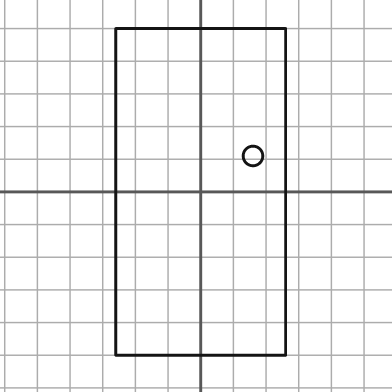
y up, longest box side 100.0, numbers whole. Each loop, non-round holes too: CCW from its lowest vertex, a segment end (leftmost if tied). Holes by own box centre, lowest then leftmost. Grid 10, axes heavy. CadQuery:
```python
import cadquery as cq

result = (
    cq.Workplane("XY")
    .moveTo(-26.0, -50.0)
    .lineTo(26.0, -50.0)
    .lineTo(26.0, 50.0)
    .lineTo(-26.0, 50.0)
    .close()
    .moveTo(16.0, 11.0)
    .circle(3.0)
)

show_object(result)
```